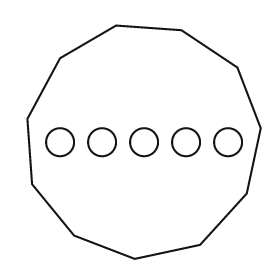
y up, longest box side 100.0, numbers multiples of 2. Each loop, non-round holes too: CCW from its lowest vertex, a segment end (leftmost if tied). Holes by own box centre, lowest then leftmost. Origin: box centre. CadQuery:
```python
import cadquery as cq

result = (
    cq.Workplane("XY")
    .moveTo(-4.0, -50.0)
    .lineTo(24.0, -44.0)
    .lineTo(44.0, -22.0)
    .lineTo(50.0, 6.0)
    .lineTo(40.0, 32.0)
    .lineTo(16.0, 48.0)
    .lineTo(-12.0, 50.0)
    .lineTo(-36.0, 36.0)
    .lineTo(-50.0, 10.0)
    .lineTo(-48.0, -18.0)
    .lineTo(-30.0, -40.0)
    .close()
    .moveTo(-36.0, 0.0)
    .circle(6.0)
    .moveTo(-18.0, 0.0)
    .circle(6.0)
    .moveTo(0.0, 0.0)
    .circle(6.0)
    .moveTo(18.0, 0.0)
    .circle(6.0)
    .moveTo(36.0, 0.0)
    .circle(6.0)
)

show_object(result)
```